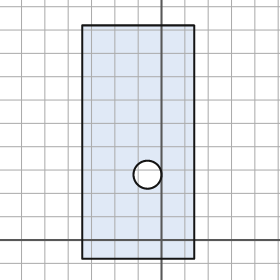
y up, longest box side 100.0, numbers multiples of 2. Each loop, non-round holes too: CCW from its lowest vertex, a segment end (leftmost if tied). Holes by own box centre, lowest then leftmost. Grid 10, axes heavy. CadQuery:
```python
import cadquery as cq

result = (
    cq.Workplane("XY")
    .moveTo(-34.0, -8.0)
    .lineTo(14.0, -8.0)
    .lineTo(14.0, 92.0)
    .lineTo(-34.0, 92.0)
    .close()
    .moveTo(-6.0, 28.0)
    .circle(6.0)
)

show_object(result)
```